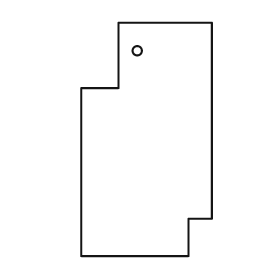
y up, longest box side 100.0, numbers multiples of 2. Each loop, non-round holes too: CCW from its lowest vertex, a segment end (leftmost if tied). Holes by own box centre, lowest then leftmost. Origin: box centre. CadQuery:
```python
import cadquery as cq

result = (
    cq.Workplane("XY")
    .moveTo(-28.0, -50.0)
    .lineTo(18.0, -50.0)
    .lineTo(18.0, -34.0)
    .lineTo(28.0, -34.0)
    .lineTo(28.0, 50.0)
    .lineTo(-12.0, 50.0)
    .lineTo(-12.0, 22.0)
    .lineTo(-28.0, 22.0)
    .close()
    .moveTo(-4.0, 38.0)
    .circle(2.0)
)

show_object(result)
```